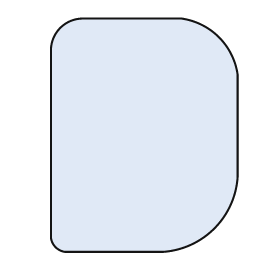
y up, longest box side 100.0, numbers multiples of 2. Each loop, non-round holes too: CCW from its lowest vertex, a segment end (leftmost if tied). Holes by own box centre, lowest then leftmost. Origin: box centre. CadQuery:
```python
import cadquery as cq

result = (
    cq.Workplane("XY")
    .moveTo(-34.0, -50.0)
    .lineTo(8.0, -50.0)
    .threePointArc((30.0, -40.0), (40.0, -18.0))
    .lineTo(40.0, 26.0)
    .threePointArc((32.0, 42.0), (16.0, 50.0))
    .lineTo(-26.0, 50.0)
    .threePointArc((-36.0, 46.0), (-40.0, 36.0))
    .lineTo(-40.0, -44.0)
    .threePointArc((-38.0, -48.0), (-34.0, -50.0))
    .close()
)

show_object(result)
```